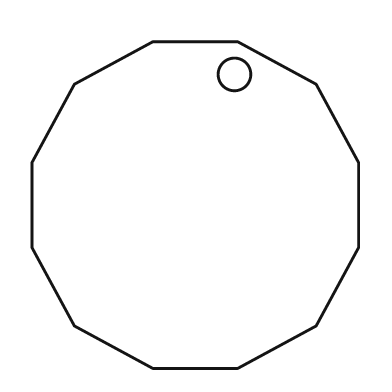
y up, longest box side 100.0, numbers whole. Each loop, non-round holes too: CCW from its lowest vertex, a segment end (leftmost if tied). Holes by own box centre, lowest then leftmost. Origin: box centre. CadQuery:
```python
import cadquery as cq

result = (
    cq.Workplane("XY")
    .moveTo(-13.0, -50.0)
    .lineTo(13.0, -50.0)
    .lineTo(37.0, -37.0)
    .lineTo(50.0, -13.0)
    .lineTo(50.0, 13.0)
    .lineTo(37.0, 37.0)
    .lineTo(13.0, 50.0)
    .lineTo(-13.0, 50.0)
    .lineTo(-37.0, 37.0)
    .lineTo(-50.0, 13.0)
    .lineTo(-50.0, -13.0)
    .lineTo(-37.0, -37.0)
    .close()
    .moveTo(12.0, 40.0)
    .circle(5.0)
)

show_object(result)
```